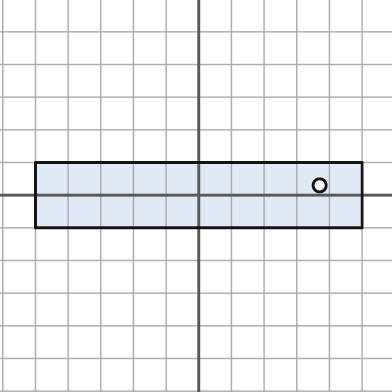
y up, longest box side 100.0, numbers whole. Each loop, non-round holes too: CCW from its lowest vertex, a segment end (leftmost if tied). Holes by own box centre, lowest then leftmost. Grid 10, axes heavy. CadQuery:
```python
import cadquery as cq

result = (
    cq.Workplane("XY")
    .moveTo(-50.0, -10.0)
    .lineTo(50.0, -10.0)
    .lineTo(50.0, 10.0)
    .lineTo(-50.0, 10.0)
    .close()
    .moveTo(37.0, 3.0)
    .circle(2.0)
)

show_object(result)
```